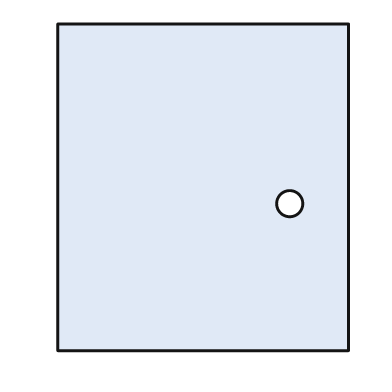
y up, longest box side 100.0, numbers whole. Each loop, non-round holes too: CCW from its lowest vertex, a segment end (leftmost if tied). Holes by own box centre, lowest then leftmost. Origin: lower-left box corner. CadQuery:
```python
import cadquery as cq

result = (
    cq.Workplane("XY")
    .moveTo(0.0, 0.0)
    .lineTo(89.0, 0.0)
    .lineTo(89.0, 100.0)
    .lineTo(0.0, 100.0)
    .close()
    .moveTo(71.0, 45.0)
    .circle(4.0)
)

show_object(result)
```